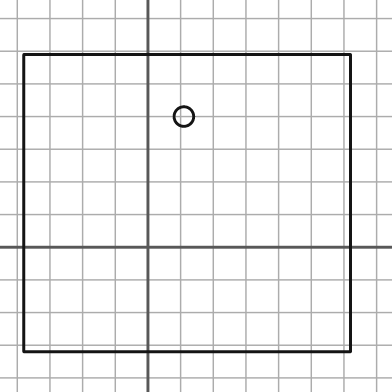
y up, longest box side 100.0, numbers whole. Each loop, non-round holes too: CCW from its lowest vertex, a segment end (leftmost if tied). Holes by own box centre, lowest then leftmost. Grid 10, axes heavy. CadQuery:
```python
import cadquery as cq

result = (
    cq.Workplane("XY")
    .moveTo(-38.0, -32.0)
    .lineTo(62.0, -32.0)
    .lineTo(62.0, 59.0)
    .lineTo(-38.0, 59.0)
    .close()
    .moveTo(11.0, 40.0)
    .circle(3.0)
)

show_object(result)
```